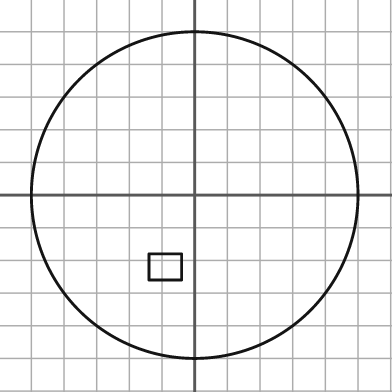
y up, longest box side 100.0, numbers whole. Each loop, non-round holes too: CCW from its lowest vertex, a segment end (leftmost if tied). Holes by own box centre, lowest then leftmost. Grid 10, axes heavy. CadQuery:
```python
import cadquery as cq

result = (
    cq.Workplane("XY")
    .moveTo(0.0, 0.0)
    .circle(50.0)
    .moveTo(-14.0, -26.0)
    .lineTo(-4.0, -26.0)
    .lineTo(-4.0, -18.0)
    .lineTo(-14.0, -18.0)
    .close()
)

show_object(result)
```